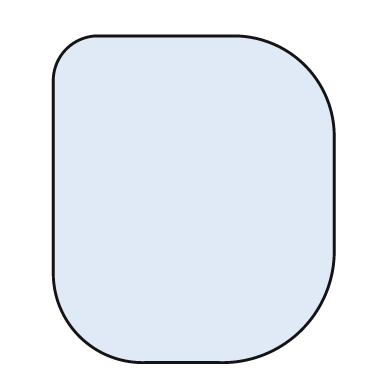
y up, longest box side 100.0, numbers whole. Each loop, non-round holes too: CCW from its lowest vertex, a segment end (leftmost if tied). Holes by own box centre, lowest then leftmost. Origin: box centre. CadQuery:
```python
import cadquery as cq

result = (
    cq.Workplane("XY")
    .moveTo(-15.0, -50.0)
    .lineTo(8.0, -50.0)
    .threePointArc((33.0, -40.0), (43.0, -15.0))
    .lineTo(43.0, 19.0)
    .threePointArc((34.0, 41.0), (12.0, 50.0))
    .lineTo(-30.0, 50.0)
    .threePointArc((-39.0, 46.0), (-43.0, 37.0))
    .lineTo(-43.0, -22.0)
    .threePointArc((-35.0, -42.0), (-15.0, -50.0))
    .close()
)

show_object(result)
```